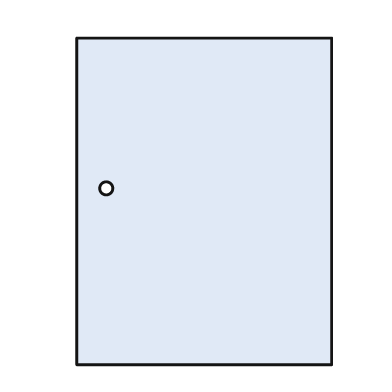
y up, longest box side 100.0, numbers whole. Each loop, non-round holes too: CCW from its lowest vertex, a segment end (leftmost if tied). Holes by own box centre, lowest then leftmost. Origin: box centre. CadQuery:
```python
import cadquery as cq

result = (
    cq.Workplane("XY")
    .moveTo(-39.0, -50.0)
    .lineTo(39.0, -50.0)
    .lineTo(39.0, 50.0)
    .lineTo(-39.0, 50.0)
    .close()
    .moveTo(-30.0, 4.0)
    .circle(2.0)
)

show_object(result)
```